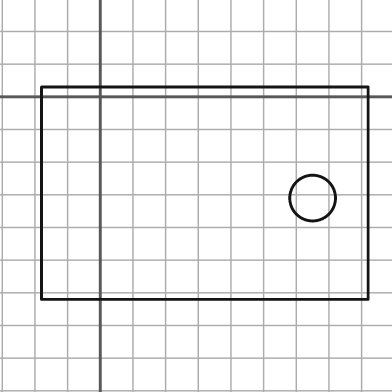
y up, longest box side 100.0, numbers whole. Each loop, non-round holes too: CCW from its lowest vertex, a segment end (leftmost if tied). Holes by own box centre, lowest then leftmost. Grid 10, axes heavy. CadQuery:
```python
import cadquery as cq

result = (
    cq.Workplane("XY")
    .moveTo(-18.0, -62.0)
    .lineTo(82.0, -62.0)
    .lineTo(82.0, 3.0)
    .lineTo(-18.0, 3.0)
    .close()
    .moveTo(65.0, -31.0)
    .circle(7.0)
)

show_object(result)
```